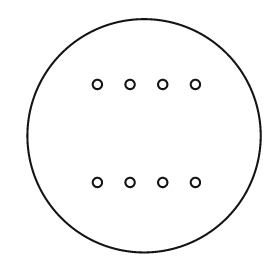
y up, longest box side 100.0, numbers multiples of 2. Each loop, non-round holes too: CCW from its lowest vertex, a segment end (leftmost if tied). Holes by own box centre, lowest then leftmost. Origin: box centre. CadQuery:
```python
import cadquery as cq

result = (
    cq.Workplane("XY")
    .moveTo(0.0, 0.0)
    .circle(50.0)
    .moveTo(-20.0, -20.0)
    .circle(2.0)
    .moveTo(-6.0, -20.0)
    .circle(2.0)
    .moveTo(8.0, -20.0)
    .circle(2.0)
    .moveTo(22.0, -20.0)
    .circle(2.0)
    .moveTo(-20.0, 22.0)
    .circle(2.0)
    .moveTo(-6.0, 22.0)
    .circle(2.0)
    .moveTo(8.0, 22.0)
    .circle(2.0)
    .moveTo(22.0, 22.0)
    .circle(2.0)
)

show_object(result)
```